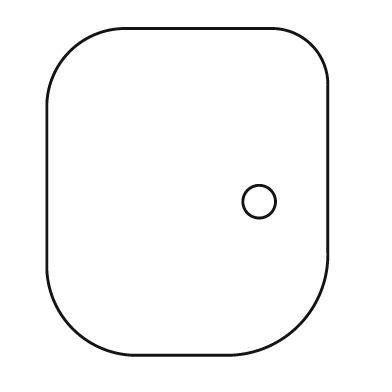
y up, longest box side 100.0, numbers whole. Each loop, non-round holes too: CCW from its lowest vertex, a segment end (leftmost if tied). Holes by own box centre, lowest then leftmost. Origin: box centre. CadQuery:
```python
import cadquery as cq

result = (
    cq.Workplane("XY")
    .moveTo(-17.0, -50.0)
    .lineTo(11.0, -50.0)
    .threePointArc((34.0, -41.0), (43.0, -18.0))
    .lineTo(43.0, 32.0)
    .threePointArc((38.0, 45.0), (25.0, 50.0))
    .lineTo(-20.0, 50.0)
    .threePointArc((-36.0, 43.0), (-43.0, 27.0))
    .lineTo(-43.0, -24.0)
    .threePointArc((-35.0, -42.0), (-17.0, -50.0))
    .close()
    .moveTo(22.0, -3.0)
    .circle(5.0)
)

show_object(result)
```